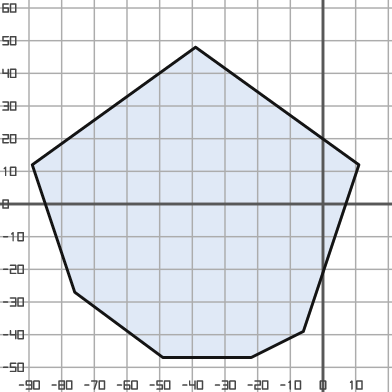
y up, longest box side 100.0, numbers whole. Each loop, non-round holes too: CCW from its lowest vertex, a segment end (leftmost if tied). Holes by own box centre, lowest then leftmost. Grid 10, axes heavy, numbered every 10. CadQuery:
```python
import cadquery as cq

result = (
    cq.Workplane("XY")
    .moveTo(-49.0, -47.0)
    .lineTo(-22.0, -47.0)
    .lineTo(-6.0, -39.0)
    .lineTo(11.0, 12.0)
    .lineTo(-39.0, 48.0)
    .lineTo(-89.0, 12.0)
    .lineTo(-76.0, -27.0)
    .close()
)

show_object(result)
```